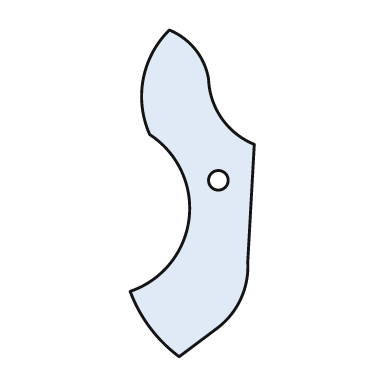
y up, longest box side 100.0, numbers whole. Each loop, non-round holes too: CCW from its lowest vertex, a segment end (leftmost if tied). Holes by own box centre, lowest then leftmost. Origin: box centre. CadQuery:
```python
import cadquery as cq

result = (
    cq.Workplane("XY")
    .moveTo(-4.0, -50.0)
    .lineTo(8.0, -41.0)
    .threePointArc((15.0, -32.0), (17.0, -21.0))
    .lineTo(19.0, 15.0)
    .threePointArc((9.0, 23.0), (5.0, 35.0))
    .threePointArc((1.0, 44.0), (-7.0, 50.0))
    .threePointArc((-15.0, 35.0), (-13.0, 18.0))
    .threePointArc((-1.0, -8.0), (-19.0, -30.0))
    .threePointArc((-13.0, -41.0), (-4.0, -50.0))
    .close()
    .moveTo(8.0, 4.0)
    .circle(3.0)
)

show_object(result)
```